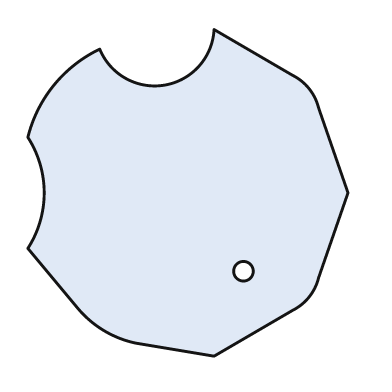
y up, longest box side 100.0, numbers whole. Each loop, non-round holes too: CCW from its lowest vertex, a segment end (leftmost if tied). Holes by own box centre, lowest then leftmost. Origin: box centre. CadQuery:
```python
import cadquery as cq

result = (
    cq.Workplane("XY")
    .moveTo(8.0, -50.0)
    .lineTo(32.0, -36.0)
    .threePointArc((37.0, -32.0), (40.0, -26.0))
    .lineTo(49.0, 0.0)
    .lineTo(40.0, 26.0)
    .threePointArc((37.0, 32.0), (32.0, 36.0))
    .lineTo(8.0, 50.0)
    .threePointArc((-7.0, 33.0), (-27.0, 44.0))
    .threePointArc((-41.0, 33.0), (-49.0, 17.0))
    .threePointArc((-44.0, 0.0), (-49.0, -17.0))
    .lineTo(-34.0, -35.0)
    .threePointArc((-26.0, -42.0), (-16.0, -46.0))
    .close()
    .moveTo(17.0, -24.0)
    .circle(3.0)
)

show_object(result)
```